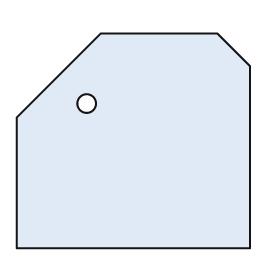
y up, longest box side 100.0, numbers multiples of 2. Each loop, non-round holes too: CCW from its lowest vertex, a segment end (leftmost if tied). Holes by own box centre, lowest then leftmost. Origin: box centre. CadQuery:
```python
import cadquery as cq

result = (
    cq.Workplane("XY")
    .moveTo(-50.0, -46.0)
    .lineTo(50.0, -46.0)
    .lineTo(50.0, 32.0)
    .lineTo(36.0, 46.0)
    .lineTo(-14.0, 46.0)
    .lineTo(-50.0, 10.0)
    .close()
    .moveTo(-20.0, 16.0)
    .circle(4.0)
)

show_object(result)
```